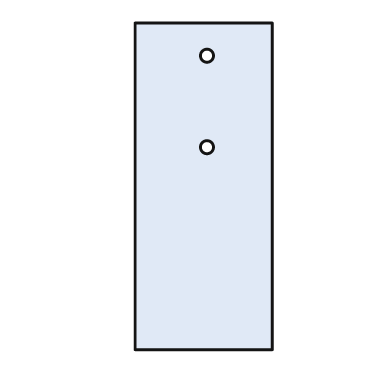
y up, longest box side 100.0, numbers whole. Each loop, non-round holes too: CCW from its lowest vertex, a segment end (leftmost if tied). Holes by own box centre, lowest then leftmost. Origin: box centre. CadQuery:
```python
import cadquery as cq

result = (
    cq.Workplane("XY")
    .moveTo(-21.0, -50.0)
    .lineTo(21.0, -50.0)
    .lineTo(21.0, 50.0)
    .lineTo(-21.0, 50.0)
    .close()
    .moveTo(1.0, 12.0)
    .circle(2.0)
    .moveTo(1.0, 40.0)
    .circle(2.0)
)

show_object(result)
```